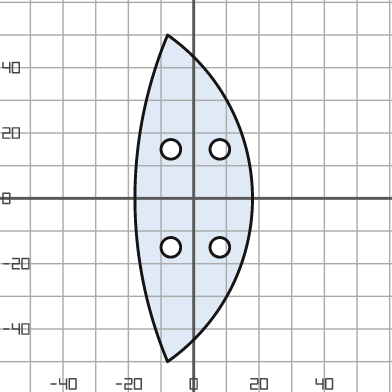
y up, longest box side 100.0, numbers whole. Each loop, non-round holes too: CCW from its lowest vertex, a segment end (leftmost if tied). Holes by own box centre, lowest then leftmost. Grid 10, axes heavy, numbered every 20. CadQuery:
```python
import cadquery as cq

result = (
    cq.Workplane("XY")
    .moveTo(-8.0, -50.0)
    .threePointArc((18.0, 0.0), (-8.0, 50.0))
    .threePointArc((-18.0, 0.0), (-8.0, -50.0))
    .close()
    .moveTo(-7.0, -15.0)
    .circle(3.0)
    .moveTo(8.0, -15.0)
    .circle(3.0)
    .moveTo(-7.0, 15.0)
    .circle(3.0)
    .moveTo(8.0, 15.0)
    .circle(3.0)
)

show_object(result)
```